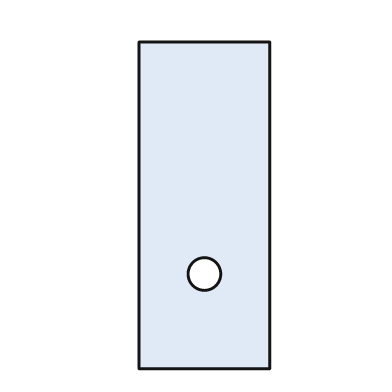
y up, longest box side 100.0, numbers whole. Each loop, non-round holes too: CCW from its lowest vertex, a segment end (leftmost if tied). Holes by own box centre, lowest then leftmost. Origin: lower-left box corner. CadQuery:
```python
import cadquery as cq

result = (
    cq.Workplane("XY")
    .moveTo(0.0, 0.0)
    .lineTo(40.0, 0.0)
    .lineTo(40.0, 100.0)
    .lineTo(0.0, 100.0)
    .close()
    .moveTo(20.0, 29.0)
    .circle(5.0)
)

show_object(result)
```